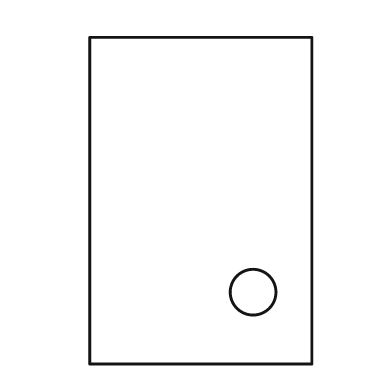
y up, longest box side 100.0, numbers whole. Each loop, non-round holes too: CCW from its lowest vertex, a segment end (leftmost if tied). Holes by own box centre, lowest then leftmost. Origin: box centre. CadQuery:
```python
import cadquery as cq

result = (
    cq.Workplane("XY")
    .moveTo(-34.0, -50.0)
    .lineTo(34.0, -50.0)
    .lineTo(34.0, 50.0)
    .lineTo(-34.0, 50.0)
    .close()
    .moveTo(16.0, -28.0)
    .circle(7.0)
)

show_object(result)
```